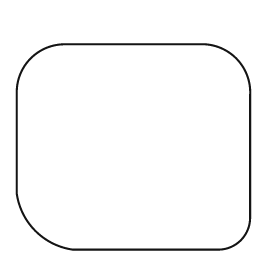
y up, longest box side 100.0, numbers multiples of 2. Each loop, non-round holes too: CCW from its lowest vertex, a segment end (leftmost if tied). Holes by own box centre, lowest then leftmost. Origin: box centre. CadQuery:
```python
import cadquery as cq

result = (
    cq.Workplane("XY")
    .moveTo(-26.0, -44.0)
    .lineTo(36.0, -44.0)
    .threePointArc((46.0, -40.0), (50.0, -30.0))
    .lineTo(50.0, 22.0)
    .threePointArc((44.0, 38.0), (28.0, 44.0))
    .lineTo(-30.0, 44.0)
    .threePointArc((-44.0, 38.0), (-50.0, 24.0))
    .lineTo(-50.0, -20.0)
    .threePointArc((-42.0, -36.0), (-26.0, -44.0))
    .close()
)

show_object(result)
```